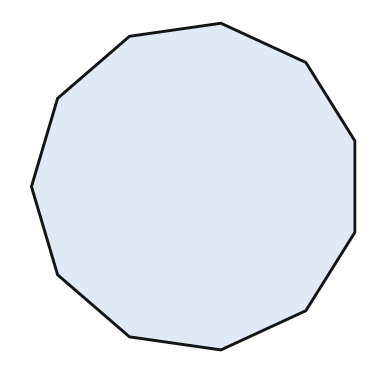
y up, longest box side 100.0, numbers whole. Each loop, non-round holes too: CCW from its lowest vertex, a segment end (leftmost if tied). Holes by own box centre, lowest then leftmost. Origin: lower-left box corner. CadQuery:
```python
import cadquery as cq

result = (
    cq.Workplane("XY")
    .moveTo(58.0, 0.0)
    .lineTo(84.0, 12.0)
    .lineTo(99.0, 36.0)
    .lineTo(99.0, 64.0)
    .lineTo(84.0, 88.0)
    .lineTo(58.0, 100.0)
    .lineTo(30.0, 96.0)
    .lineTo(8.0, 77.0)
    .lineTo(0.0, 50.0)
    .lineTo(8.0, 23.0)
    .lineTo(30.0, 4.0)
    .close()
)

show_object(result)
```